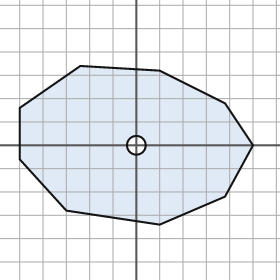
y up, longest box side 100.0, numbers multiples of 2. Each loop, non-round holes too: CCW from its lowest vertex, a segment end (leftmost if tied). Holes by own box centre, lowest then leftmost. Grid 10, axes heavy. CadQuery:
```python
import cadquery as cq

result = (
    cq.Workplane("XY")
    .moveTo(10.0, -34.0)
    .lineTo(38.0, -22.0)
    .lineTo(50.0, 0.0)
    .lineTo(38.0, 18.0)
    .lineTo(10.0, 32.0)
    .lineTo(-24.0, 34.0)
    .lineTo(-50.0, 16.0)
    .lineTo(-50.0, -6.0)
    .lineTo(-30.0, -28.0)
    .close()
    .moveTo(0.0, 0.0)
    .circle(4.0)
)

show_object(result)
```